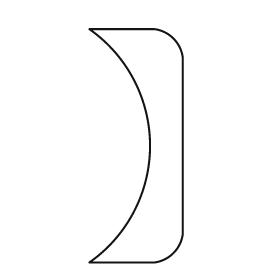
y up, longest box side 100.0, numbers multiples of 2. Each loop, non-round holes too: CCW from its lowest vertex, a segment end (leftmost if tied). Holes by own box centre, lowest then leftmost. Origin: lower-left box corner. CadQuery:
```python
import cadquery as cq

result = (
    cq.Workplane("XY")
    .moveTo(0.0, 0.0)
    .lineTo(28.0, 0.0)
    .threePointArc((36.0, 4.0), (40.0, 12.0))
    .lineTo(40.0, 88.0)
    .threePointArc((36.0, 96.0), (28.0, 100.0))
    .lineTo(0.0, 100.0)
    .threePointArc((26.0, 50.0), (0.0, 0.0))
    .close()
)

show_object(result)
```